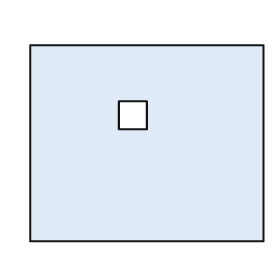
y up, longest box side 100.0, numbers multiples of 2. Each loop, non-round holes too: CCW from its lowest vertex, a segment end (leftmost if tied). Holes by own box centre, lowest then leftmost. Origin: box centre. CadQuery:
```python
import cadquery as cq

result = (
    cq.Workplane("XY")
    .moveTo(-50.0, -42.0)
    .lineTo(50.0, -42.0)
    .lineTo(50.0, 42.0)
    .lineTo(-50.0, 42.0)
    .close()
    .moveTo(-12.0, 6.0)
    .lineTo(0.0, 6.0)
    .lineTo(0.0, 18.0)
    .lineTo(-12.0, 18.0)
    .close()
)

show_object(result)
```